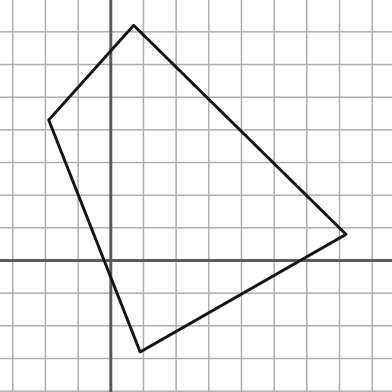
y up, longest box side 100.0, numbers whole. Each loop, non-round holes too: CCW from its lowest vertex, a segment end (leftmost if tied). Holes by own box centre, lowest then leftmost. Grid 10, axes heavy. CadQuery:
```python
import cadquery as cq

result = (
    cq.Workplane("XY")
    .moveTo(9.0, -28.0)
    .lineTo(72.0, 8.0)
    .lineTo(7.0, 72.0)
    .lineTo(-19.0, 43.0)
    .close()
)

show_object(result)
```